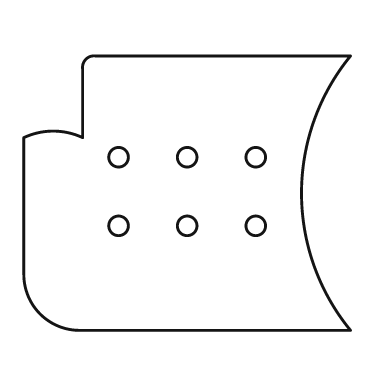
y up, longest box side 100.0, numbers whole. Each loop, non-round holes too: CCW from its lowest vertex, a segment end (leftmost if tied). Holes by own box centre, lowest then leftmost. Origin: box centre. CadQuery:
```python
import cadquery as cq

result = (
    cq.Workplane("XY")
    .moveTo(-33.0, -42.0)
    .lineTo(50.0, -42.0)
    .threePointArc((35.0, 0.0), (50.0, 42.0))
    .lineTo(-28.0, 42.0)
    .threePointArc((-31.0, 41.0), (-32.0, 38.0))
    .lineTo(-32.0, 17.0)
    .threePointArc((-41.0, 19.0), (-50.0, 17.0))
    .lineTo(-50.0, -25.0)
    .threePointArc((-45.0, -37.0), (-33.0, -42.0))
    .close()
    .moveTo(-21.0, -10.0)
    .circle(3.0)
    .moveTo(0.0, -10.0)
    .circle(3.0)
    .moveTo(21.0, -10.0)
    .circle(3.0)
    .moveTo(-21.0, 11.0)
    .circle(3.0)
    .moveTo(0.0, 11.0)
    .circle(3.0)
    .moveTo(21.0, 11.0)
    .circle(3.0)
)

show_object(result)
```